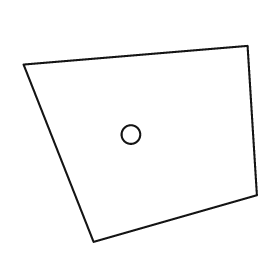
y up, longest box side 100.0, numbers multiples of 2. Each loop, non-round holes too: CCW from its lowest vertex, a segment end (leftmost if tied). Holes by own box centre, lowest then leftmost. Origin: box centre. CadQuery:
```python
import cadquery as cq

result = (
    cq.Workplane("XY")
    .moveTo(-20.0, -42.0)
    .lineTo(50.0, -22.0)
    .lineTo(46.0, 42.0)
    .lineTo(-50.0, 34.0)
    .close()
    .moveTo(-4.0, 4.0)
    .circle(4.0)
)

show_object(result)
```